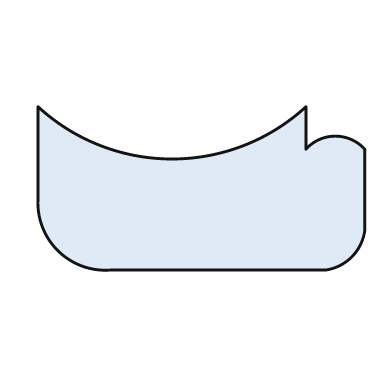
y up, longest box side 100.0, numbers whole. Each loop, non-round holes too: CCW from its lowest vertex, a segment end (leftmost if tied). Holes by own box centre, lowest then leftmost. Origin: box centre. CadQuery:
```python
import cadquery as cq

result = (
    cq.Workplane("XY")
    .moveTo(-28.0, -25.0)
    .lineTo(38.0, -25.0)
    .threePointArc((46.0, -21.0), (50.0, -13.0))
    .lineTo(50.0, 12.0)
    .threePointArc((41.0, 16.0), (32.0, 12.0))
    .lineTo(32.0, 25.0)
    .threePointArc((-9.0, 9.0), (-50.0, 25.0))
    .lineTo(-50.0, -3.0)
    .threePointArc((-44.0, -19.0), (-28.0, -25.0))
    .close()
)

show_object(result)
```